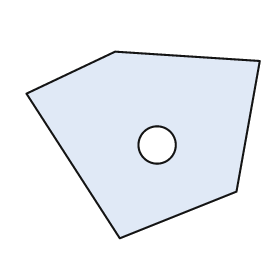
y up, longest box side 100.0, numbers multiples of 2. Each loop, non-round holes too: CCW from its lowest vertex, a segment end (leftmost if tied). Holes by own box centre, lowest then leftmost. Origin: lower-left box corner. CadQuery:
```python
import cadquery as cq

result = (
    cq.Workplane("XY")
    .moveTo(40.0, 0.0)
    .lineTo(90.0, 20.0)
    .lineTo(100.0, 76.0)
    .lineTo(38.0, 80.0)
    .lineTo(0.0, 62.0)
    .close()
    .moveTo(56.0, 40.0)
    .circle(8.0)
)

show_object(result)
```